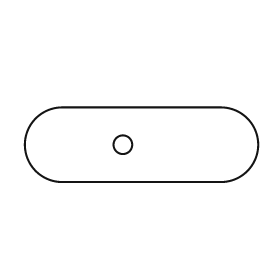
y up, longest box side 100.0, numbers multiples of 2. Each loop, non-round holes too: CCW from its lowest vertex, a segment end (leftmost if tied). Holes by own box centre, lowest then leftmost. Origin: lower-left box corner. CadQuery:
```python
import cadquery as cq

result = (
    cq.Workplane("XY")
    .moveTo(16.0, 0.0)
    .lineTo(84.0, 0.0)
    .threePointArc((100.0, 16.0), (84.0, 32.0))
    .lineTo(16.0, 32.0)
    .threePointArc((0.0, 16.0), (16.0, 0.0))
    .close()
    .moveTo(42.0, 16.0)
    .circle(4.0)
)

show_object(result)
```